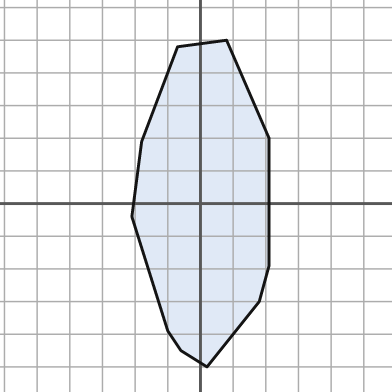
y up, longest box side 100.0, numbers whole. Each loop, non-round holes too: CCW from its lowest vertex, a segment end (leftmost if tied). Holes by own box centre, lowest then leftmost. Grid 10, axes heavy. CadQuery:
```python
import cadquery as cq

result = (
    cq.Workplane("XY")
    .moveTo(2.0, -50.0)
    .lineTo(18.0, -30.0)
    .lineTo(21.0, -19.0)
    .lineTo(21.0, 20.0)
    .lineTo(8.0, 50.0)
    .lineTo(-7.0, 48.0)
    .lineTo(-18.0, 19.0)
    .lineTo(-21.0, -4.0)
    .lineTo(-10.0, -39.0)
    .lineTo(-6.0, -45.0)
    .close()
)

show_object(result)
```